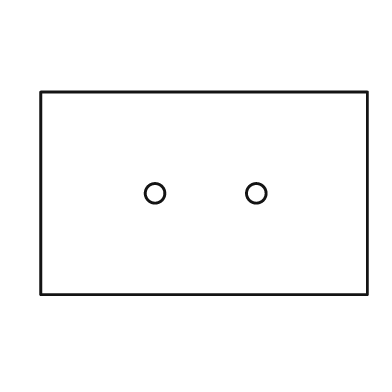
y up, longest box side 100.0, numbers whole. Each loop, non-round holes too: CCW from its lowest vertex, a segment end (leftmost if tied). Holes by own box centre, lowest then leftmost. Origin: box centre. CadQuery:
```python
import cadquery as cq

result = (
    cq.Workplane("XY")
    .moveTo(-50.0, -31.0)
    .lineTo(50.0, -31.0)
    .lineTo(50.0, 31.0)
    .lineTo(-50.0, 31.0)
    .close()
    .moveTo(-15.0, 0.0)
    .circle(3.0)
    .moveTo(16.0, 0.0)
    .circle(3.0)
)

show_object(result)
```